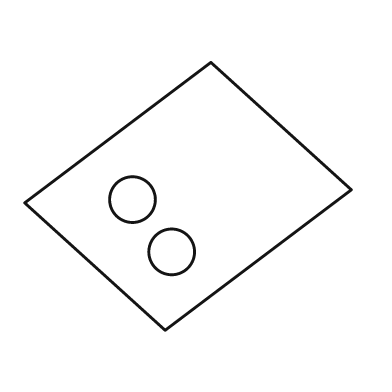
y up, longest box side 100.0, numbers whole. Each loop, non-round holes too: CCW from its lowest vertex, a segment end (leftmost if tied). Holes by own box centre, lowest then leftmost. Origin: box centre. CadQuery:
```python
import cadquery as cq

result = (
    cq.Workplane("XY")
    .moveTo(-7.0, -41.0)
    .lineTo(50.0, 2.0)
    .lineTo(7.0, 41.0)
    .lineTo(-50.0, -2.0)
    .close()
    .moveTo(-5.0, -17.0)
    .circle(7.0)
    .moveTo(-17.0, -1.0)
    .circle(7.0)
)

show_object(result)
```